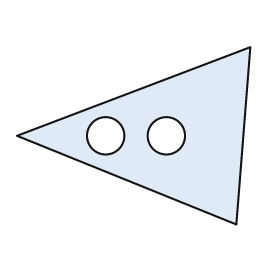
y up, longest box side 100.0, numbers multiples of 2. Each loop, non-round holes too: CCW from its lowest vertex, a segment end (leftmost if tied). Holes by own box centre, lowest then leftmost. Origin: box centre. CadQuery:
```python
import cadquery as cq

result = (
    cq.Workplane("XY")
    .moveTo(44.0, -38.0)
    .lineTo(50.0, 38.0)
    .lineTo(-50.0, 0.0)
    .close()
    .moveTo(-12.0, 0.0)
    .circle(8.0)
    .moveTo(14.0, 0.0)
    .circle(8.0)
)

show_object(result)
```